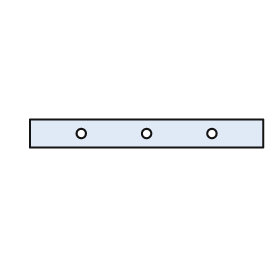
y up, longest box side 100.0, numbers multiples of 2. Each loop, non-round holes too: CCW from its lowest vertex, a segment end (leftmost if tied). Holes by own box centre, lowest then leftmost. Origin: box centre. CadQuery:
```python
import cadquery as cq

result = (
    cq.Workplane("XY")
    .moveTo(-50.0, -6.0)
    .lineTo(50.0, -6.0)
    .lineTo(50.0, 6.0)
    .lineTo(-50.0, 6.0)
    .close()
    .moveTo(-28.0, 0.0)
    .circle(2.0)
    .moveTo(0.0, 0.0)
    .circle(2.0)
    .moveTo(28.0, 0.0)
    .circle(2.0)
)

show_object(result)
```